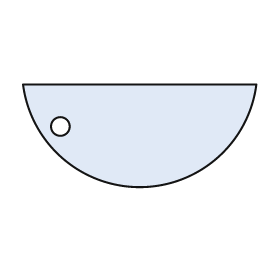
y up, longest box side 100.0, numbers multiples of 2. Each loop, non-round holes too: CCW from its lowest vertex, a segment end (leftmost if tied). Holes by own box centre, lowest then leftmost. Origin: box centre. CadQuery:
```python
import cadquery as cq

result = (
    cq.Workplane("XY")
    .moveTo(-50.0, 22.0)
    .threePointArc((0.0, -22.0), (50.0, 22.0))
    .close()
    .moveTo(-34.0, 4.0)
    .circle(4.0)
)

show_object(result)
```